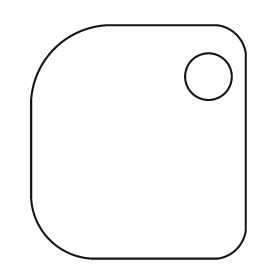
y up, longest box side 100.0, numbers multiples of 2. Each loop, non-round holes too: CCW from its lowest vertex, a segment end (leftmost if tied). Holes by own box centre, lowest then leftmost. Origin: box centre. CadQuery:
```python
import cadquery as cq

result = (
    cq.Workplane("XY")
    .moveTo(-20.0, -50.0)
    .lineTo(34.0, -50.0)
    .threePointArc((42.0, -46.0), (46.0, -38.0))
    .lineTo(46.0, 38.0)
    .threePointArc((42.0, 46.0), (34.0, 50.0))
    .lineTo(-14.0, 50.0)
    .threePointArc((-36.0, 40.0), (-46.0, 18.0))
    .lineTo(-46.0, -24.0)
    .threePointArc((-38.0, -42.0), (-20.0, -50.0))
    .close()
    .moveTo(30.0, 28.0)
    .circle(10.0)
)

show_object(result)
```